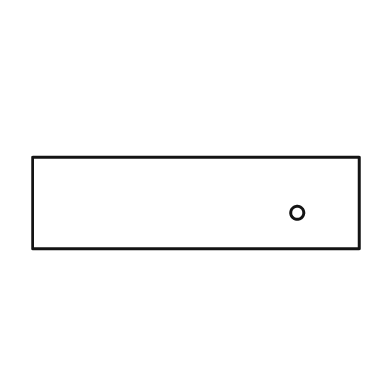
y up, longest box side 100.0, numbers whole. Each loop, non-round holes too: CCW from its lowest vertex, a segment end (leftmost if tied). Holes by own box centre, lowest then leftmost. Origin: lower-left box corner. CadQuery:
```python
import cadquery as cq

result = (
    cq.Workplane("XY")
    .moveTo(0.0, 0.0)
    .lineTo(100.0, 0.0)
    .lineTo(100.0, 28.0)
    .lineTo(0.0, 28.0)
    .close()
    .moveTo(81.0, 11.0)
    .circle(2.0)
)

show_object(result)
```